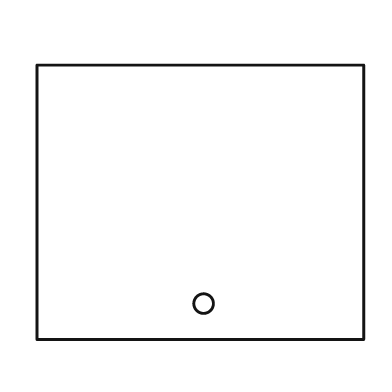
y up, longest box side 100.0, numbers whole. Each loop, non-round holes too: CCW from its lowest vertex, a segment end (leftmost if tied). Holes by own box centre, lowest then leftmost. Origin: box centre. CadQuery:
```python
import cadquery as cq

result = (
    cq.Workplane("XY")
    .moveTo(-50.0, -42.0)
    .lineTo(50.0, -42.0)
    .lineTo(50.0, 42.0)
    .lineTo(-50.0, 42.0)
    .close()
    .moveTo(1.0, -31.0)
    .circle(3.0)
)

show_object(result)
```